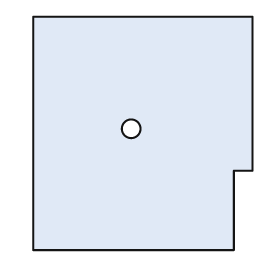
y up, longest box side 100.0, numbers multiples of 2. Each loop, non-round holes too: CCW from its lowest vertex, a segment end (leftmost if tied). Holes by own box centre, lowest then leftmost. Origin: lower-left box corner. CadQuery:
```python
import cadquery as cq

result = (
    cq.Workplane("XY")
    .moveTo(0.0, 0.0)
    .lineTo(86.0, 0.0)
    .lineTo(86.0, 34.0)
    .lineTo(94.0, 34.0)
    .lineTo(94.0, 100.0)
    .lineTo(0.0, 100.0)
    .close()
    .moveTo(42.0, 52.0)
    .circle(4.0)
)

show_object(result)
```